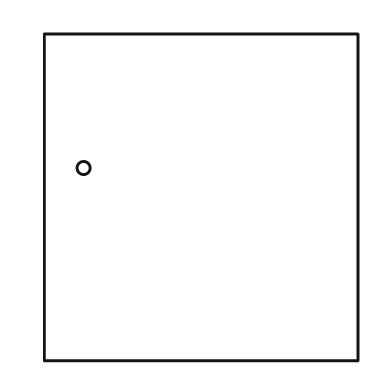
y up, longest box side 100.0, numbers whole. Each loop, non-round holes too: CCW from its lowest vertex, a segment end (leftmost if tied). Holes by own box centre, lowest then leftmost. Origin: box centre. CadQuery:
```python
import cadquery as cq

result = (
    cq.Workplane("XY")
    .moveTo(-48.0, -50.0)
    .lineTo(48.0, -50.0)
    .lineTo(48.0, 50.0)
    .lineTo(-48.0, 50.0)
    .close()
    .moveTo(-36.0, 9.0)
    .circle(2.0)
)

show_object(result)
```